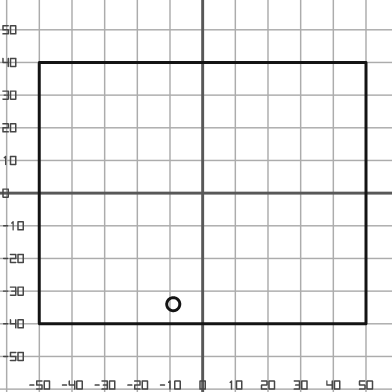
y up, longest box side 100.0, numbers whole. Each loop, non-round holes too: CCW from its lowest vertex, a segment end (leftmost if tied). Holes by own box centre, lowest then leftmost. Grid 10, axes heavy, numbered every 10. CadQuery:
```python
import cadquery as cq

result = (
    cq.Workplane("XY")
    .moveTo(-50.0, -40.0)
    .lineTo(50.0, -40.0)
    .lineTo(50.0, 40.0)
    .lineTo(-50.0, 40.0)
    .close()
    .moveTo(-9.0, -34.0)
    .circle(2.0)
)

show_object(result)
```